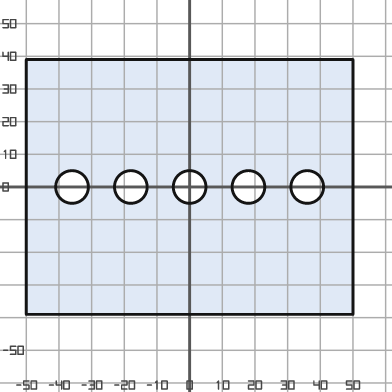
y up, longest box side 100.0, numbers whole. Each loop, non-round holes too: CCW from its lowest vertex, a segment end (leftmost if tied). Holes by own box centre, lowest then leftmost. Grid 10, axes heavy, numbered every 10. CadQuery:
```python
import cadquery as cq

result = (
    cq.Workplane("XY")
    .moveTo(-50.0, -39.0)
    .lineTo(50.0, -39.0)
    .lineTo(50.0, 39.0)
    .lineTo(-50.0, 39.0)
    .close()
    .moveTo(-36.0, 0.0)
    .circle(5.0)
    .moveTo(-18.0, 0.0)
    .circle(5.0)
    .moveTo(0.0, 0.0)
    .circle(5.0)
    .moveTo(18.0, 0.0)
    .circle(5.0)
    .moveTo(36.0, 0.0)
    .circle(5.0)
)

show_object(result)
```